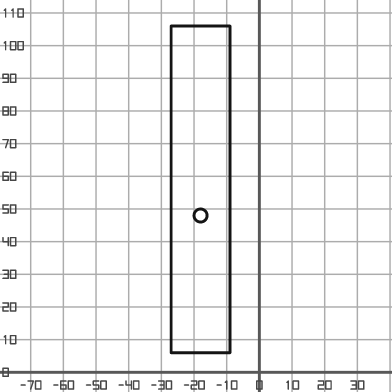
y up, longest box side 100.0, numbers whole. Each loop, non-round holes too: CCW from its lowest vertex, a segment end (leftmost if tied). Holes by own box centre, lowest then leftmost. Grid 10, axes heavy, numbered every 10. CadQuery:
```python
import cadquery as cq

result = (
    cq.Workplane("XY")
    .moveTo(-27.0, 6.0)
    .lineTo(-9.0, 6.0)
    .lineTo(-9.0, 106.0)
    .lineTo(-27.0, 106.0)
    .close()
    .moveTo(-18.0, 48.0)
    .circle(2.0)
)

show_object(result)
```